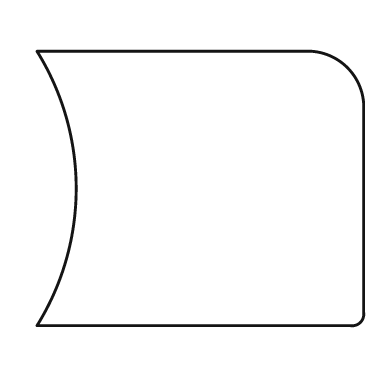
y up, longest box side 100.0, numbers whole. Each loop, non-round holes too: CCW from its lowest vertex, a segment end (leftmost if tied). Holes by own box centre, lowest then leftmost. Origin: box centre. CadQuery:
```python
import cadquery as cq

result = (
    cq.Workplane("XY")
    .moveTo(-50.0, -42.0)
    .lineTo(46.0, -42.0)
    .threePointArc((49.0, -41.0), (50.0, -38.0))
    .lineTo(50.0, 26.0)
    .threePointArc((45.0, 37.0), (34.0, 42.0))
    .lineTo(-50.0, 42.0)
    .threePointArc((-38.0, 0.0), (-50.0, -42.0))
    .close()
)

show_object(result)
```